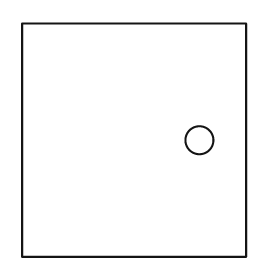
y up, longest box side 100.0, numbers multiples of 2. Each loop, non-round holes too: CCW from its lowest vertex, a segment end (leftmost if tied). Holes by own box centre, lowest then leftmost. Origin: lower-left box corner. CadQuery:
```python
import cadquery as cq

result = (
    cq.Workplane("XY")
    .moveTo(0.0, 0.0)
    .lineTo(96.0, 0.0)
    .lineTo(96.0, 100.0)
    .lineTo(0.0, 100.0)
    .close()
    .moveTo(76.0, 50.0)
    .circle(6.0)
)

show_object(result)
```